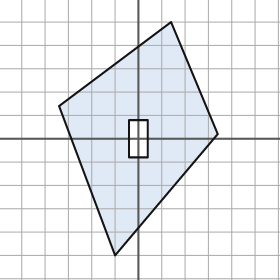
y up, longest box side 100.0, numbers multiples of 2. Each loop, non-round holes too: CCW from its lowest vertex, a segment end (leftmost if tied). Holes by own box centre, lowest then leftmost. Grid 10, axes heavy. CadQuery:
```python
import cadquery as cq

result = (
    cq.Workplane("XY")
    .moveTo(-10.0, -50.0)
    .lineTo(34.0, 2.0)
    .lineTo(14.0, 50.0)
    .lineTo(-34.0, 14.0)
    .close()
    .moveTo(-4.0, -8.0)
    .lineTo(4.0, -8.0)
    .lineTo(4.0, 8.0)
    .lineTo(-4.0, 8.0)
    .close()
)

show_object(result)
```